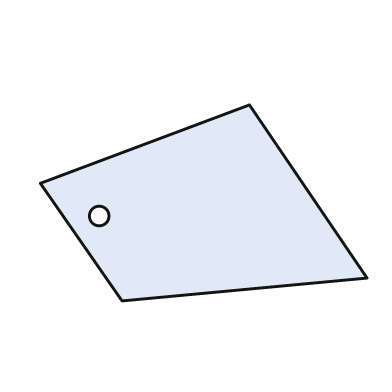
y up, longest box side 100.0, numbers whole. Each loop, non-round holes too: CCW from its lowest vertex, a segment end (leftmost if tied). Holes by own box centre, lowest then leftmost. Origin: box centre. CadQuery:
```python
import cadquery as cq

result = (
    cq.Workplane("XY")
    .moveTo(-25.0, -30.0)
    .lineTo(50.0, -23.0)
    .lineTo(14.0, 30.0)
    .lineTo(-50.0, 6.0)
    .close()
    .moveTo(-32.0, -4.0)
    .circle(3.0)
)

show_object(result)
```